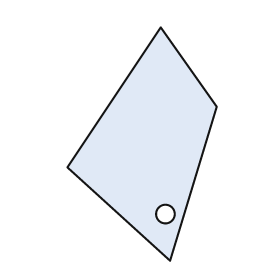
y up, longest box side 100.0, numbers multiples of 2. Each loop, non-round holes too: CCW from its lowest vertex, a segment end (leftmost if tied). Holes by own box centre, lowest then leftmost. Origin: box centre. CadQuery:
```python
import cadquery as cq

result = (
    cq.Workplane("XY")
    .moveTo(12.0, -50.0)
    .lineTo(32.0, 16.0)
    .lineTo(8.0, 50.0)
    .lineTo(-32.0, -10.0)
    .close()
    .moveTo(10.0, -30.0)
    .circle(4.0)
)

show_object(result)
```